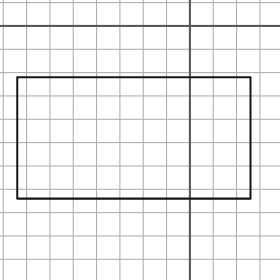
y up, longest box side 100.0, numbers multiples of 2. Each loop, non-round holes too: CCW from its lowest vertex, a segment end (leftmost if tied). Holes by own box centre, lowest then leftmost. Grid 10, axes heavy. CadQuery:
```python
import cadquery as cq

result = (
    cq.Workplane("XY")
    .moveTo(-74.0, -74.0)
    .lineTo(26.0, -74.0)
    .lineTo(26.0, -22.0)
    .lineTo(-74.0, -22.0)
    .close()
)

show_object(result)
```